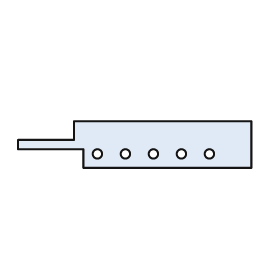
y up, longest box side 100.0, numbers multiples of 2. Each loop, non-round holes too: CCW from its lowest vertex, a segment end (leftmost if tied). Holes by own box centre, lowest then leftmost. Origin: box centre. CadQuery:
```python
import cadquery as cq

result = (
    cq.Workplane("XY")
    .moveTo(-22.0, -10.0)
    .lineTo(50.0, -10.0)
    .lineTo(50.0, 10.0)
    .lineTo(-26.0, 10.0)
    .lineTo(-26.0, 2.0)
    .lineTo(-50.0, 2.0)
    .lineTo(-50.0, -2.0)
    .lineTo(-22.0, -2.0)
    .close()
    .moveTo(-16.0, -4.0)
    .circle(2.0)
    .moveTo(-4.0, -4.0)
    .circle(2.0)
    .moveTo(8.0, -4.0)
    .circle(2.0)
    .moveTo(20.0, -4.0)
    .circle(2.0)
    .moveTo(32.0, -4.0)
    .circle(2.0)
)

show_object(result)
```